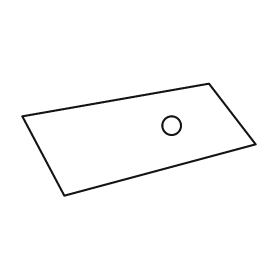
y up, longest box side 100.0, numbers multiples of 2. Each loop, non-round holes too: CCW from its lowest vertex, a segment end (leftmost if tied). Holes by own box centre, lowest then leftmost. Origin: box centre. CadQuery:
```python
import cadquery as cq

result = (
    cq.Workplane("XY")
    .moveTo(-32.0, -24.0)
    .lineTo(50.0, -2.0)
    .lineTo(30.0, 24.0)
    .lineTo(-50.0, 10.0)
    .close()
    .moveTo(14.0, 6.0)
    .circle(4.0)
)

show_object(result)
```